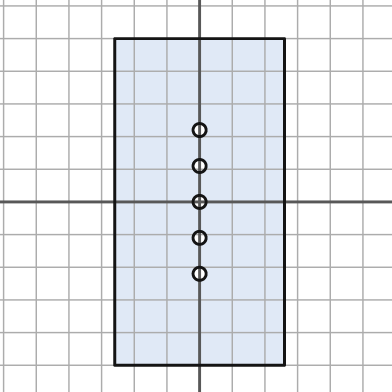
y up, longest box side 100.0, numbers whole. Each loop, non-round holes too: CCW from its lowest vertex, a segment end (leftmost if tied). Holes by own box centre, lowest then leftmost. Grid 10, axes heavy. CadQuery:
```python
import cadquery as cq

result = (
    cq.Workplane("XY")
    .moveTo(-26.0, -50.0)
    .lineTo(26.0, -50.0)
    .lineTo(26.0, 50.0)
    .lineTo(-26.0, 50.0)
    .close()
    .moveTo(0.0, -22.0)
    .circle(2.0)
    .moveTo(0.0, -11.0)
    .circle(2.0)
    .moveTo(0.0, 0.0)
    .circle(2.0)
    .moveTo(0.0, 11.0)
    .circle(2.0)
    .moveTo(0.0, 22.0)
    .circle(2.0)
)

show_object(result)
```